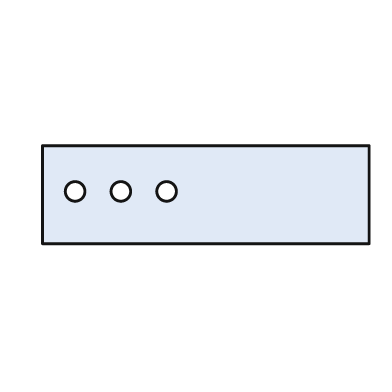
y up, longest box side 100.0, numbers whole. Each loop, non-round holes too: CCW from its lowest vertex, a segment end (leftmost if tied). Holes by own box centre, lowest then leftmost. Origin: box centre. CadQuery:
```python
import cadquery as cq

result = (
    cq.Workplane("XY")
    .moveTo(-50.0, -15.0)
    .lineTo(50.0, -15.0)
    .lineTo(50.0, 15.0)
    .lineTo(-50.0, 15.0)
    .close()
    .moveTo(-40.0, 1.0)
    .circle(3.0)
    .moveTo(-26.0, 1.0)
    .circle(3.0)
    .moveTo(-12.0, 1.0)
    .circle(3.0)
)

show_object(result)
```